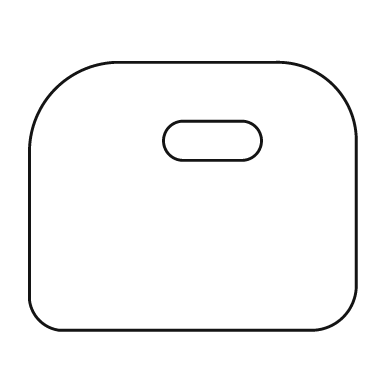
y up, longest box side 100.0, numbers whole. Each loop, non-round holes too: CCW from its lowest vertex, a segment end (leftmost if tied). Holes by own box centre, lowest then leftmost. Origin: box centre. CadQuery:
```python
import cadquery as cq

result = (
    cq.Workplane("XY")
    .moveTo(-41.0, -41.0)
    .lineTo(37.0, -41.0)
    .threePointArc((46.0, -37.0), (50.0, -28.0))
    .lineTo(50.0, 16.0)
    .threePointArc((43.0, 34.0), (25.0, 41.0))
    .lineTo(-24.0, 41.0)
    .threePointArc((-42.0, 33.0), (-50.0, 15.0))
    .lineTo(-50.0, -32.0)
    .threePointArc((-47.0, -38.0), (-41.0, -41.0))
    .close()
    .moveTo(-3.0, 11.0)
    .lineTo(15.0, 11.0)
    .threePointArc((21.0, 17.0), (15.0, 23.0))
    .lineTo(-3.0, 23.0)
    .threePointArc((-9.0, 17.0), (-3.0, 11.0))
    .close()
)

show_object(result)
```